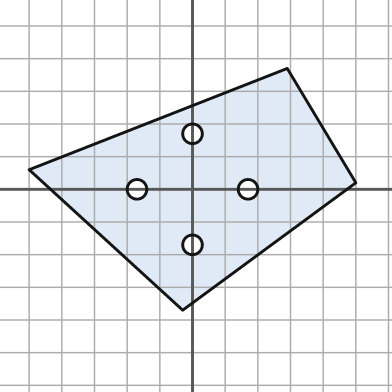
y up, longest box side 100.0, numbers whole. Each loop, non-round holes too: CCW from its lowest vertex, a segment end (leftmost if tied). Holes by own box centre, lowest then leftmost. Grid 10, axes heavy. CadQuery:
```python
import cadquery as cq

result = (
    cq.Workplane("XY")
    .moveTo(-3.0, -37.0)
    .lineTo(50.0, 2.0)
    .lineTo(29.0, 37.0)
    .lineTo(-50.0, 6.0)
    .close()
    .moveTo(0.0, -17.0)
    .circle(3.0)
    .moveTo(-17.0, 0.0)
    .circle(3.0)
    .moveTo(17.0, 0.0)
    .circle(3.0)
    .moveTo(0.0, 17.0)
    .circle(3.0)
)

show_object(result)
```